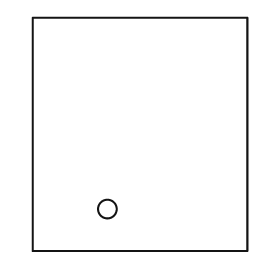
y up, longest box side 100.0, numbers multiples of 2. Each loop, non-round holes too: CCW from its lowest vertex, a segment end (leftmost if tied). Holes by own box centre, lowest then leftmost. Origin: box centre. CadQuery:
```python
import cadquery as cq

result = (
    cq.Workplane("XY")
    .moveTo(-46.0, -50.0)
    .lineTo(46.0, -50.0)
    .lineTo(46.0, 50.0)
    .lineTo(-46.0, 50.0)
    .close()
    .moveTo(-14.0, -32.0)
    .circle(4.0)
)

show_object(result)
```